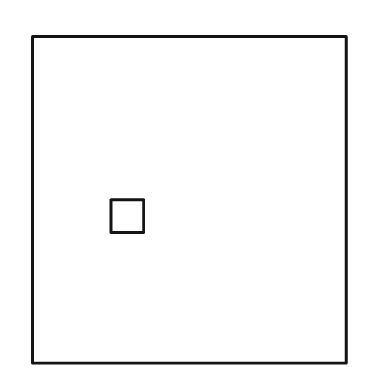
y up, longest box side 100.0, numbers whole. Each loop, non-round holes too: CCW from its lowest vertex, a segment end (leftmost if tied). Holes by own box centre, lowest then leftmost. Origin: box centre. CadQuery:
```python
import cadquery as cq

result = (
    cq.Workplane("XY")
    .moveTo(-48.0, -50.0)
    .lineTo(48.0, -50.0)
    .lineTo(48.0, 50.0)
    .lineTo(-48.0, 50.0)
    .close()
    .moveTo(-24.0, -10.0)
    .lineTo(-14.0, -10.0)
    .lineTo(-14.0, 0.0)
    .lineTo(-24.0, 0.0)
    .close()
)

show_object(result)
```